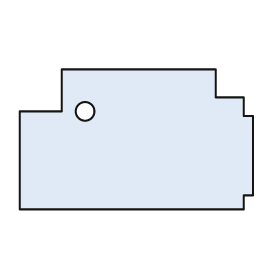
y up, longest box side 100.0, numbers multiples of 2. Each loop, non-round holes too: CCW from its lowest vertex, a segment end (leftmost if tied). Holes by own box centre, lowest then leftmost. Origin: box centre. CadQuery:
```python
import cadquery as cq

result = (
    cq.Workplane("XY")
    .moveTo(-50.0, -30.0)
    .lineTo(46.0, -30.0)
    .lineTo(46.0, -24.0)
    .lineTo(50.0, -24.0)
    .lineTo(50.0, 10.0)
    .lineTo(46.0, 10.0)
    .lineTo(46.0, 18.0)
    .lineTo(34.0, 18.0)
    .lineTo(34.0, 30.0)
    .lineTo(-32.0, 30.0)
    .lineTo(-32.0, 12.0)
    .lineTo(-50.0, 12.0)
    .close()
    .moveTo(-22.0, 12.0)
    .circle(4.0)
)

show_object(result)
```